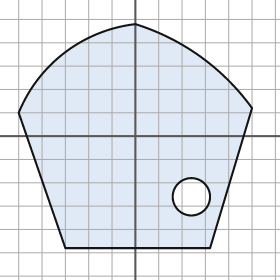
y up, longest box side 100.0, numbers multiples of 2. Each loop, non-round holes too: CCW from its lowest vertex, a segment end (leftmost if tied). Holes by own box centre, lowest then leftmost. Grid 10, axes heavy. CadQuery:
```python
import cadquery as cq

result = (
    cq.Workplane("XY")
    .moveTo(-30.0, -48.0)
    .lineTo(32.0, -48.0)
    .lineTo(50.0, 12.0)
    .threePointArc((28.0, 34.0), (0.0, 48.0))
    .threePointArc((-30.0, 36.0), (-50.0, 10.0))
    .close()
    .moveTo(24.0, -26.0)
    .circle(8.0)
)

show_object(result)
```